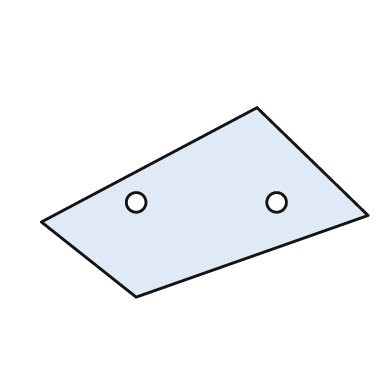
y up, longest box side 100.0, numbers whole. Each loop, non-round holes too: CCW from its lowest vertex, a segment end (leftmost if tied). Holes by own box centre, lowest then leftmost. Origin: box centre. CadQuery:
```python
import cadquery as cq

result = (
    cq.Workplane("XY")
    .moveTo(-21.0, -29.0)
    .lineTo(50.0, -4.0)
    .lineTo(16.0, 29.0)
    .lineTo(-50.0, -6.0)
    .close()
    .moveTo(-21.0, 0.0)
    .circle(3.0)
    .moveTo(22.0, 0.0)
    .circle(3.0)
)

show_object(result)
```